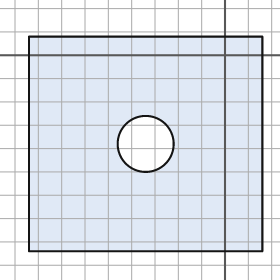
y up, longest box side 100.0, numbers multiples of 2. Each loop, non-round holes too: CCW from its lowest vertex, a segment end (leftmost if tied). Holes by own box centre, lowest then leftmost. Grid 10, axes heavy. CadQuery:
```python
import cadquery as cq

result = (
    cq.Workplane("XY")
    .moveTo(-84.0, -84.0)
    .lineTo(16.0, -84.0)
    .lineTo(16.0, 8.0)
    .lineTo(-84.0, 8.0)
    .close()
    .moveTo(-34.0, -38.0)
    .circle(12.0)
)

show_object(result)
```